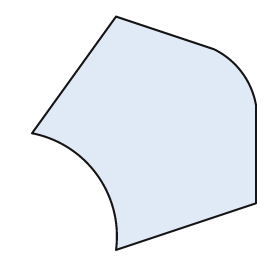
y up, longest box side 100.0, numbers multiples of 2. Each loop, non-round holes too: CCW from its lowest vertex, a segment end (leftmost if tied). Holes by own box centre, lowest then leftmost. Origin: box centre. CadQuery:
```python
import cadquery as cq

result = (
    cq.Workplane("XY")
    .moveTo(-12.0, -50.0)
    .lineTo(48.0, -30.0)
    .lineTo(48.0, 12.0)
    .threePointArc((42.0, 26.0), (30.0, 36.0))
    .lineTo(-12.0, 50.0)
    .lineTo(-48.0, 0.0)
    .threePointArc((-20.0, -18.0), (-12.0, -50.0))
    .close()
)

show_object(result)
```